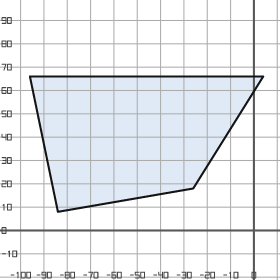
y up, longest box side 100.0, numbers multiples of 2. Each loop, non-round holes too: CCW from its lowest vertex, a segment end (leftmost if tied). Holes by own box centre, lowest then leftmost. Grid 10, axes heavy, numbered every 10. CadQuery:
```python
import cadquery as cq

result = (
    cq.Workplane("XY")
    .moveTo(-84.0, 8.0)
    .lineTo(-26.0, 18.0)
    .lineTo(4.0, 66.0)
    .lineTo(-96.0, 66.0)
    .close()
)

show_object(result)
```